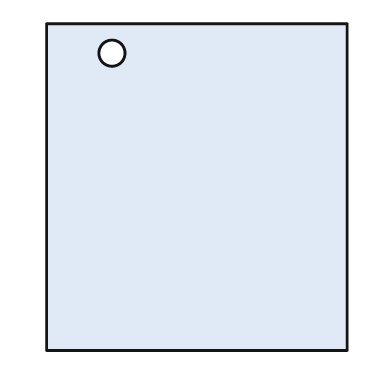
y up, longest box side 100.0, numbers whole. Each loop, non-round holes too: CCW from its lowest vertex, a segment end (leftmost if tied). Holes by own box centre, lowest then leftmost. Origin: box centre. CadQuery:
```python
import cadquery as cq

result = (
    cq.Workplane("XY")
    .moveTo(-46.0, -50.0)
    .lineTo(46.0, -50.0)
    .lineTo(46.0, 50.0)
    .lineTo(-46.0, 50.0)
    .close()
    .moveTo(-26.0, 41.0)
    .circle(4.0)
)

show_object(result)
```